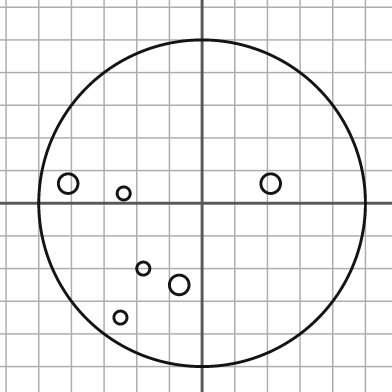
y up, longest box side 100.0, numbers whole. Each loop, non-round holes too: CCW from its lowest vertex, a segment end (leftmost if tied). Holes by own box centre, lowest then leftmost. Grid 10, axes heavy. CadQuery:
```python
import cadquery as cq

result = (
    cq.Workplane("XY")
    .moveTo(0.0, 0.0)
    .circle(50.0)
    .moveTo(-25.0, -35.0)
    .circle(2.0)
    .moveTo(-7.0, -25.0)
    .circle(3.0)
    .moveTo(-18.0, -20.0)
    .circle(2.0)
    .moveTo(-24.0, 3.0)
    .circle(2.0)
    .moveTo(-41.0, 6.0)
    .circle(3.0)
    .moveTo(21.0, 6.0)
    .circle(3.0)
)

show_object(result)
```